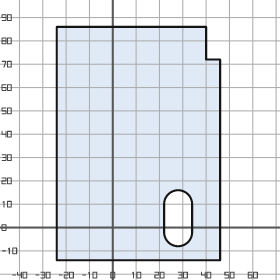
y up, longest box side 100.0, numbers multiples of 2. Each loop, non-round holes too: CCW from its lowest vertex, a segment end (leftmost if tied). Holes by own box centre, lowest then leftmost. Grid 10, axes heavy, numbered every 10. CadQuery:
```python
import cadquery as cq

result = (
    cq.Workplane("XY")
    .moveTo(-24.0, -14.0)
    .lineTo(46.0, -14.0)
    .lineTo(46.0, 72.0)
    .lineTo(40.0, 72.0)
    .lineTo(40.0, 86.0)
    .lineTo(-24.0, 86.0)
    .close()
    .moveTo(22.0, -2.0)
    .threePointArc((28.0, -8.0), (34.0, -2.0))
    .lineTo(34.0, 10.0)
    .threePointArc((28.0, 16.0), (22.0, 10.0))
    .close()
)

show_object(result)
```